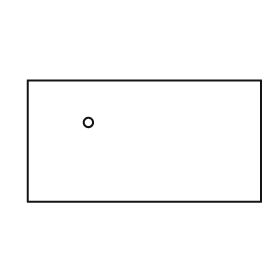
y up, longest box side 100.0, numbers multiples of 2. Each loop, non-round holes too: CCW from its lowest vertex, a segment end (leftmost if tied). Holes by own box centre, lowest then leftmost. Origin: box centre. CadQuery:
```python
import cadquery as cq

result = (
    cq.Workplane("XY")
    .moveTo(-50.0, -26.0)
    .lineTo(50.0, -26.0)
    .lineTo(50.0, 26.0)
    .lineTo(-50.0, 26.0)
    .close()
    .moveTo(-24.0, 8.0)
    .circle(2.0)
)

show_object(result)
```